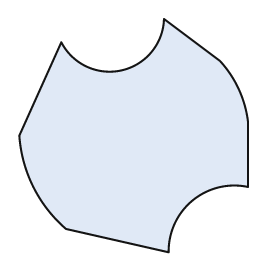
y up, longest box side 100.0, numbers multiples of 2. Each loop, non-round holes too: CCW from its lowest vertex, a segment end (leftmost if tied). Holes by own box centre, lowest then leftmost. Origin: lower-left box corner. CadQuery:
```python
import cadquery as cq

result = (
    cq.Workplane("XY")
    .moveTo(64.0, 0.0)
    .threePointArc((74.0, 22.0), (98.0, 28.0))
    .lineTo(98.0, 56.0)
    .threePointArc((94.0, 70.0), (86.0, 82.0))
    .lineTo(62.0, 100.0)
    .threePointArc((44.0, 78.0), (18.0, 90.0))
    .lineTo(0.0, 50.0)
    .threePointArc((6.0, 28.0), (20.0, 10.0))
    .close()
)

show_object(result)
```